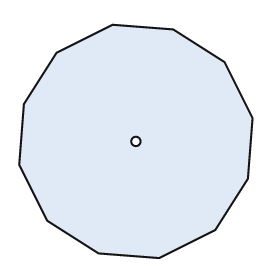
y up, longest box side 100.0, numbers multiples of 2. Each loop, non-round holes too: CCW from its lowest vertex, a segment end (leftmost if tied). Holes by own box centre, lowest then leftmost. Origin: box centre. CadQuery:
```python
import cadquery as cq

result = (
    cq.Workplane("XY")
    .moveTo(10.0, -50.0)
    .lineTo(34.0, -38.0)
    .lineTo(48.0, -16.0)
    .lineTo(50.0, 10.0)
    .lineTo(38.0, 34.0)
    .lineTo(16.0, 48.0)
    .lineTo(-10.0, 50.0)
    .lineTo(-34.0, 38.0)
    .lineTo(-48.0, 16.0)
    .lineTo(-50.0, -10.0)
    .lineTo(-38.0, -34.0)
    .lineTo(-16.0, -48.0)
    .close()
    .moveTo(0.0, 0.0)
    .circle(2.0)
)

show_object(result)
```